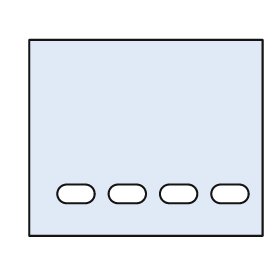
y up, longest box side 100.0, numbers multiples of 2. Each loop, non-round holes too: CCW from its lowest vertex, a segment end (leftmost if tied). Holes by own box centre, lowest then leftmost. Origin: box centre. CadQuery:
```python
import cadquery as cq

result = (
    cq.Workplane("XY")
    .moveTo(-50.0, -42.0)
    .lineTo(50.0, -42.0)
    .lineTo(50.0, 42.0)
    .lineTo(-50.0, 42.0)
    .close()
    .moveTo(-34.0, -28.0)
    .lineTo(-26.0, -28.0)
    .threePointArc((-22.0, -24.0), (-26.0, -20.0))
    .lineTo(-34.0, -20.0)
    .threePointArc((-38.0, -24.0), (-34.0, -28.0))
    .close()
    .moveTo(-12.0, -28.0)
    .lineTo(-4.0, -28.0)
    .threePointArc((0.0, -24.0), (-4.0, -20.0))
    .lineTo(-12.0, -20.0)
    .threePointArc((-16.0, -24.0), (-12.0, -28.0))
    .close()
    .moveTo(10.0, -28.0)
    .lineTo(18.0, -28.0)
    .threePointArc((22.0, -24.0), (18.0, -20.0))
    .lineTo(10.0, -20.0)
    .threePointArc((6.0, -24.0), (10.0, -28.0))
    .close()
    .moveTo(32.0, -28.0)
    .lineTo(40.0, -28.0)
    .threePointArc((44.0, -24.0), (40.0, -20.0))
    .lineTo(32.0, -20.0)
    .threePointArc((28.0, -24.0), (32.0, -28.0))
    .close()
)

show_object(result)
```